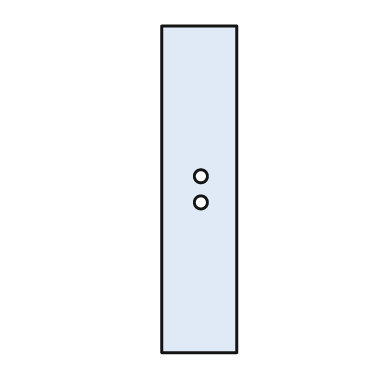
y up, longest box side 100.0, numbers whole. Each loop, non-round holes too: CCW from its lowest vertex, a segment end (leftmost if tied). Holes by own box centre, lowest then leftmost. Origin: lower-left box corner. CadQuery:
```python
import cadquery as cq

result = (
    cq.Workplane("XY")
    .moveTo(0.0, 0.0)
    .lineTo(23.0, 0.0)
    .lineTo(23.0, 100.0)
    .lineTo(0.0, 100.0)
    .close()
    .moveTo(12.0, 46.0)
    .circle(2.0)
    .moveTo(12.0, 54.0)
    .circle(2.0)
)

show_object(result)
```